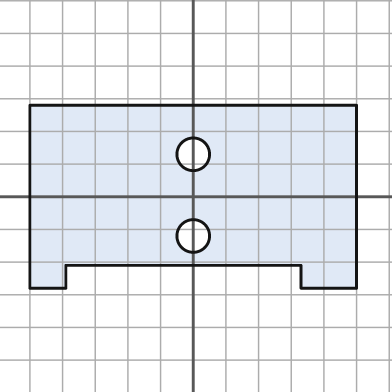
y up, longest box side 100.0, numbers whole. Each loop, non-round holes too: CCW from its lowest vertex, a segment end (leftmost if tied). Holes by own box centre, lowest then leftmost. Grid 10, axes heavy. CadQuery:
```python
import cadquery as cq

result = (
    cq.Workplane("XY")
    .moveTo(-50.0, -28.0)
    .lineTo(-39.0, -28.0)
    .lineTo(-39.0, -21.0)
    .lineTo(33.0, -21.0)
    .lineTo(33.0, -28.0)
    .lineTo(50.0, -28.0)
    .lineTo(50.0, 28.0)
    .lineTo(-50.0, 28.0)
    .close()
    .moveTo(0.0, -12.0)
    .circle(5.0)
    .moveTo(0.0, 13.0)
    .circle(5.0)
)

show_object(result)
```